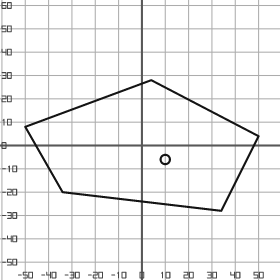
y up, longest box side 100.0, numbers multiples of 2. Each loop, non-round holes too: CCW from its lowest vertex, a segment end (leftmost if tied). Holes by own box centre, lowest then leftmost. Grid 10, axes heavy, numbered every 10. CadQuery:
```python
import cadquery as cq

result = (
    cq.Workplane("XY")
    .moveTo(34.0, -28.0)
    .lineTo(50.0, 4.0)
    .lineTo(4.0, 28.0)
    .lineTo(-50.0, 8.0)
    .lineTo(-34.0, -20.0)
    .close()
    .moveTo(10.0, -6.0)
    .circle(2.0)
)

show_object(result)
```